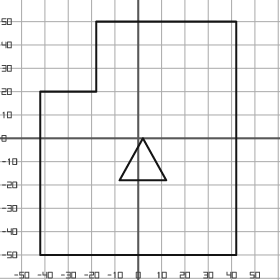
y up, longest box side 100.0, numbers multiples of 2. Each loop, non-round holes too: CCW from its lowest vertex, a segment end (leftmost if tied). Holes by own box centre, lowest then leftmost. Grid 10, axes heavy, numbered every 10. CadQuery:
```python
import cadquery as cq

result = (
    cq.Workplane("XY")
    .moveTo(-42.0, -50.0)
    .lineTo(42.0, -50.0)
    .lineTo(42.0, 50.0)
    .lineTo(-18.0, 50.0)
    .lineTo(-18.0, 20.0)
    .lineTo(-42.0, 20.0)
    .close()
    .moveTo(-8.0, -18.0)
    .lineTo(12.0, -18.0)
    .lineTo(2.0, 0.0)
    .close()
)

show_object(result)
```